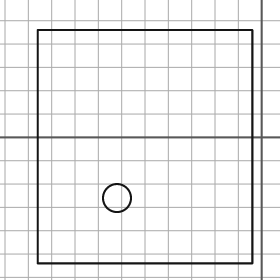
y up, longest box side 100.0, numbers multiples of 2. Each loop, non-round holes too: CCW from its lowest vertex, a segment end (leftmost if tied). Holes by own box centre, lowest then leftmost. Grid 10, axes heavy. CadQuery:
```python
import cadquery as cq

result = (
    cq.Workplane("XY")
    .moveTo(-96.0, -54.0)
    .lineTo(-4.0, -54.0)
    .lineTo(-4.0, 46.0)
    .lineTo(-96.0, 46.0)
    .close()
    .moveTo(-62.0, -26.0)
    .circle(6.0)
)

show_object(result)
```